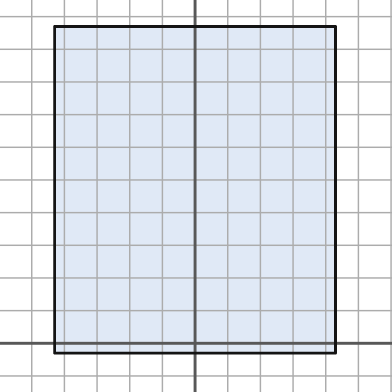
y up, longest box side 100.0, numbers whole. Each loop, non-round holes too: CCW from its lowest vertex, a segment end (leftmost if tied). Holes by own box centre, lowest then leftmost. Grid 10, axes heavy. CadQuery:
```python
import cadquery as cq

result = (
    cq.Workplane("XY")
    .moveTo(-43.0, -3.0)
    .lineTo(43.0, -3.0)
    .lineTo(43.0, 97.0)
    .lineTo(-43.0, 97.0)
    .close()
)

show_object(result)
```